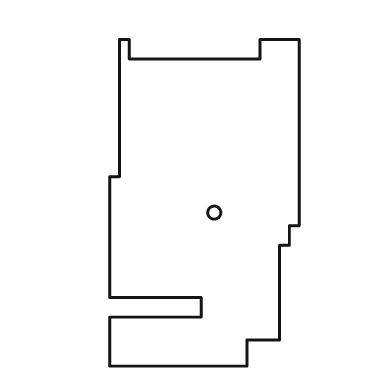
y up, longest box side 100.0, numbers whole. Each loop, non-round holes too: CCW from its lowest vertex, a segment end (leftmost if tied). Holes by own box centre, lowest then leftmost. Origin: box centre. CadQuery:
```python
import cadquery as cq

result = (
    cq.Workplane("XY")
    .moveTo(-29.0, -50.0)
    .lineTo(13.0, -50.0)
    .lineTo(13.0, -42.0)
    .lineTo(23.0, -42.0)
    .lineTo(23.0, -13.0)
    .lineTo(26.0, -13.0)
    .lineTo(26.0, -7.0)
    .lineTo(29.0, -7.0)
    .lineTo(29.0, 50.0)
    .lineTo(17.0, 50.0)
    .lineTo(17.0, 44.0)
    .lineTo(-23.0, 44.0)
    .lineTo(-23.0, 50.0)
    .lineTo(-26.0, 50.0)
    .lineTo(-26.0, 8.0)
    .lineTo(-29.0, 8.0)
    .lineTo(-29.0, -29.0)
    .lineTo(-1.0, -29.0)
    .lineTo(-1.0, -35.0)
    .lineTo(-29.0, -35.0)
    .close()
    .moveTo(3.0, -3.0)
    .circle(2.0)
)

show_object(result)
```